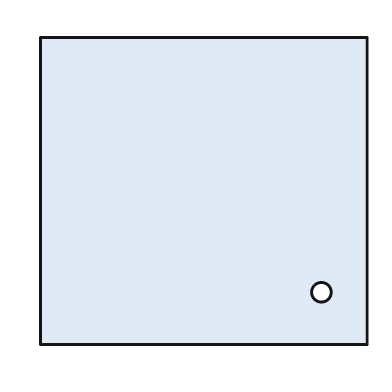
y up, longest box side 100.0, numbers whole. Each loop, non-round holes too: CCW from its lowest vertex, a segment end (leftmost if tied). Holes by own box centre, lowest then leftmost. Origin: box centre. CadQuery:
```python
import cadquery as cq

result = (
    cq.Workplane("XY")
    .moveTo(-50.0, -47.0)
    .lineTo(50.0, -47.0)
    .lineTo(50.0, 47.0)
    .lineTo(-50.0, 47.0)
    .close()
    .moveTo(36.0, -31.0)
    .circle(3.0)
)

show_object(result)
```